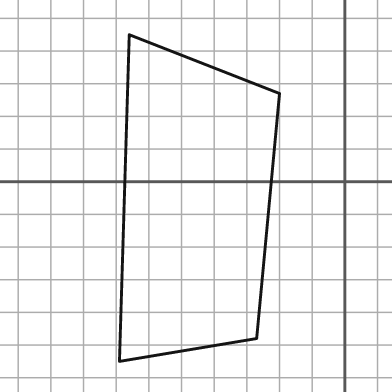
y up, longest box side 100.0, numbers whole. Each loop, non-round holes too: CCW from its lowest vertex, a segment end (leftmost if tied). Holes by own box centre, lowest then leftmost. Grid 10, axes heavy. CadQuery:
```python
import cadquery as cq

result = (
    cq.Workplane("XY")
    .moveTo(-69.0, -55.0)
    .lineTo(-27.0, -48.0)
    .lineTo(-20.0, 27.0)
    .lineTo(-66.0, 45.0)
    .close()
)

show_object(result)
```